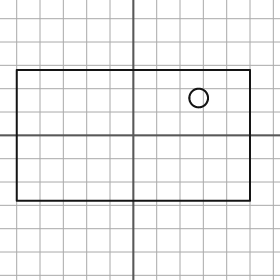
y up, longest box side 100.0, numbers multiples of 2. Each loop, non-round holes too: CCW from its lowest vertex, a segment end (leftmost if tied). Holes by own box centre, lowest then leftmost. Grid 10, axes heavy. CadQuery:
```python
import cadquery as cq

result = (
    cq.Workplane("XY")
    .moveTo(-50.0, -28.0)
    .lineTo(50.0, -28.0)
    .lineTo(50.0, 28.0)
    .lineTo(-50.0, 28.0)
    .close()
    .moveTo(28.0, 16.0)
    .circle(4.0)
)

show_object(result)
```